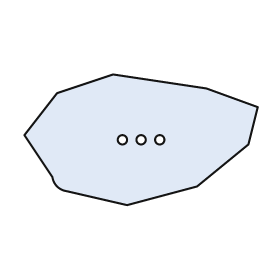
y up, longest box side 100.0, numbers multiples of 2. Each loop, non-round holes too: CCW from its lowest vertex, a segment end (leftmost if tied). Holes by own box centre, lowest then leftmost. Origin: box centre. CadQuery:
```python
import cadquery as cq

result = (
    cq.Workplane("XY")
    .moveTo(-6.0, -28.0)
    .lineTo(24.0, -20.0)
    .lineTo(46.0, -2.0)
    .lineTo(50.0, 14.0)
    .lineTo(28.0, 22.0)
    .lineTo(-12.0, 28.0)
    .lineTo(-36.0, 20.0)
    .lineTo(-50.0, 2.0)
    .lineTo(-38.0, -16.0)
    .threePointArc((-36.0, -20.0), (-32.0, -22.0))
    .close()
    .moveTo(-8.0, 0.0)
    .circle(2.0)
    .moveTo(0.0, 0.0)
    .circle(2.0)
    .moveTo(8.0, 0.0)
    .circle(2.0)
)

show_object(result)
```